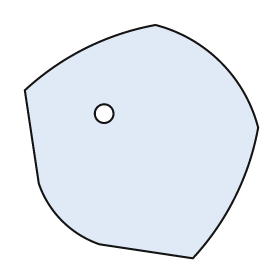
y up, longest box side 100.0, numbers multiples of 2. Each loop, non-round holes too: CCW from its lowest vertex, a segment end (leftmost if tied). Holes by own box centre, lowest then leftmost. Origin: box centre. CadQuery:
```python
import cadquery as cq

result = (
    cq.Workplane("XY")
    .moveTo(22.0, -50.0)
    .threePointArc((40.0, -24.0), (50.0, 6.0))
    .threePointArc((34.0, 34.0), (6.0, 50.0))
    .threePointArc((-24.0, 40.0), (-50.0, 22.0))
    .lineTo(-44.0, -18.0)
    .threePointArc((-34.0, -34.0), (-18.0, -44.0))
    .close()
    .moveTo(-16.0, 12.0)
    .circle(4.0)
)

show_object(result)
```